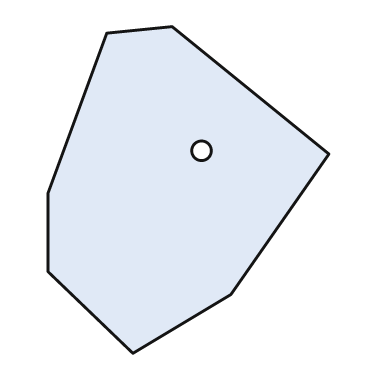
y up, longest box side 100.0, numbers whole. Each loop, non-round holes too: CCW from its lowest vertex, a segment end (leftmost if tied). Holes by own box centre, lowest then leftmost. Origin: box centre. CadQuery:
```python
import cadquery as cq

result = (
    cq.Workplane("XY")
    .moveTo(-17.0, -50.0)
    .lineTo(13.0, -32.0)
    .lineTo(43.0, 11.0)
    .lineTo(-5.0, 50.0)
    .lineTo(-25.0, 48.0)
    .lineTo(-43.0, -1.0)
    .lineTo(-43.0, -25.0)
    .close()
    .moveTo(4.0, 12.0)
    .circle(3.0)
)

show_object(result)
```